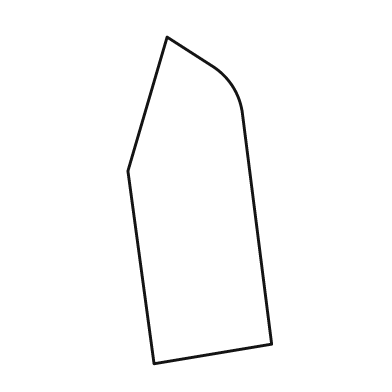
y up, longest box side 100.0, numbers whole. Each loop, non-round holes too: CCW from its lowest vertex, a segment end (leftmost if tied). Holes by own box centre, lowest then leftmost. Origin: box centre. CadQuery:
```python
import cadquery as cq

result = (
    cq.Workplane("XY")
    .moveTo(-14.0, -50.0)
    .lineTo(22.0, -44.0)
    .lineTo(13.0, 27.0)
    .threePointArc((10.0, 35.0), (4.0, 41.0))
    .lineTo(-10.0, 50.0)
    .lineTo(-22.0, 9.0)
    .close()
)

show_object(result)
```